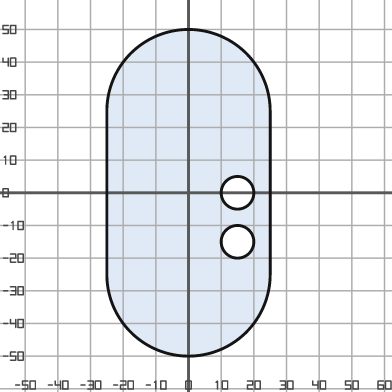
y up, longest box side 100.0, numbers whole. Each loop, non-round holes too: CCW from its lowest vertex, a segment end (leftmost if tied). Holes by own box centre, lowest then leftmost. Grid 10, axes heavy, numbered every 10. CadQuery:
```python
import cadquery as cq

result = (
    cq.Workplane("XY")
    .moveTo(-25.0, -25.0)
    .threePointArc((0.0, -50.0), (25.0, -25.0))
    .lineTo(25.0, 25.0)
    .threePointArc((0.0, 50.0), (-25.0, 25.0))
    .close()
    .moveTo(15.0, -15.0)
    .circle(5.0)
    .moveTo(15.0, 0.0)
    .circle(5.0)
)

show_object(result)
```